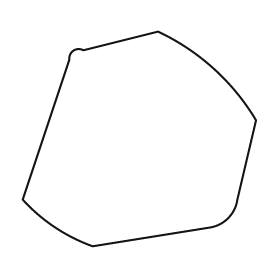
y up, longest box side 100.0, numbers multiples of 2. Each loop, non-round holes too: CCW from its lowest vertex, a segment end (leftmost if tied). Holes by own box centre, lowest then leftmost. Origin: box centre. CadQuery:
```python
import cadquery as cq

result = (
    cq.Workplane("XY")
    .moveTo(-20.0, -46.0)
    .lineTo(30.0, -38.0)
    .threePointArc((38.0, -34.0), (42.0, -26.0))
    .lineTo(50.0, 8.0)
    .threePointArc((32.0, 30.0), (8.0, 46.0))
    .lineTo(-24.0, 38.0)
    .threePointArc((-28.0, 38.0), (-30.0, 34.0))
    .lineTo(-50.0, -26.0)
    .threePointArc((-36.0, -38.0), (-20.0, -46.0))
    .close()
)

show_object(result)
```